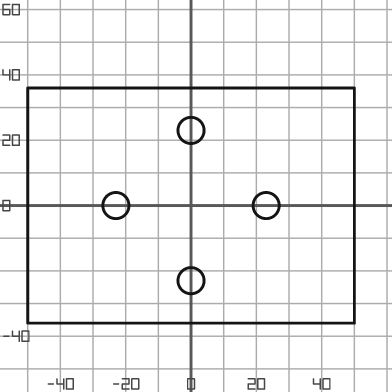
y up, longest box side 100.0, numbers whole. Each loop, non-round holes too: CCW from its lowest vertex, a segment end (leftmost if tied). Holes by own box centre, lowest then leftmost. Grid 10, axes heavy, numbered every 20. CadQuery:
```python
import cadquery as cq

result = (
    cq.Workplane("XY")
    .moveTo(-50.0, -36.0)
    .lineTo(50.0, -36.0)
    .lineTo(50.0, 36.0)
    .lineTo(-50.0, 36.0)
    .close()
    .moveTo(0.0, -23.0)
    .circle(4.0)
    .moveTo(-23.0, 0.0)
    .circle(4.0)
    .moveTo(23.0, 0.0)
    .circle(4.0)
    .moveTo(0.0, 23.0)
    .circle(4.0)
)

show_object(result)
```